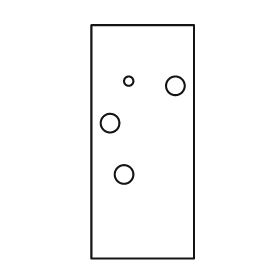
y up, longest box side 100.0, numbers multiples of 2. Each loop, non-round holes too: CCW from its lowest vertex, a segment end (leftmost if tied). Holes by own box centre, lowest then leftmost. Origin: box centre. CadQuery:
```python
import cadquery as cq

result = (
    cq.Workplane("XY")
    .moveTo(-22.0, -50.0)
    .lineTo(22.0, -50.0)
    .lineTo(22.0, 50.0)
    .lineTo(-22.0, 50.0)
    .close()
    .moveTo(-8.0, -14.0)
    .circle(4.0)
    .moveTo(-14.0, 8.0)
    .circle(4.0)
    .moveTo(14.0, 24.0)
    .circle(4.0)
    .moveTo(-6.0, 26.0)
    .circle(2.0)
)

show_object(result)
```